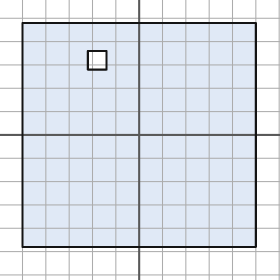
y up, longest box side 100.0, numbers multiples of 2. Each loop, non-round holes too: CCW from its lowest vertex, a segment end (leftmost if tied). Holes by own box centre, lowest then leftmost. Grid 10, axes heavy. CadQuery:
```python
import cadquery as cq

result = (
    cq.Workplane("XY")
    .moveTo(-50.0, -48.0)
    .lineTo(50.0, -48.0)
    .lineTo(50.0, 48.0)
    .lineTo(-50.0, 48.0)
    .close()
    .moveTo(-22.0, 28.0)
    .lineTo(-14.0, 28.0)
    .lineTo(-14.0, 36.0)
    .lineTo(-22.0, 36.0)
    .close()
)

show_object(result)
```